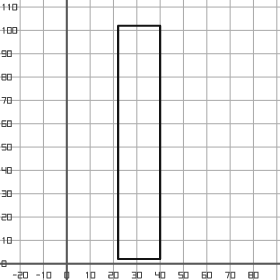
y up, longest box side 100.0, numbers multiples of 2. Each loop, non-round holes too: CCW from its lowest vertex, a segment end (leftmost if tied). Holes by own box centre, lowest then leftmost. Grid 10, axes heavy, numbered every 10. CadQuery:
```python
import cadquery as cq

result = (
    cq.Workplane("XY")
    .moveTo(22.0, 2.0)
    .lineTo(40.0, 2.0)
    .lineTo(40.0, 102.0)
    .lineTo(22.0, 102.0)
    .close()
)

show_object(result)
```